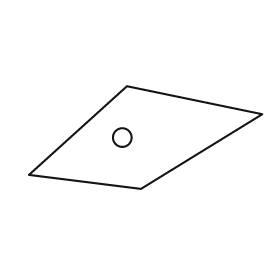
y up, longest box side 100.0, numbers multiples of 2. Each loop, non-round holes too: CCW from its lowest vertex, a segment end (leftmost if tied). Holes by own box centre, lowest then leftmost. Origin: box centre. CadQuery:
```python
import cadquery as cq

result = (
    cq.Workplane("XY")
    .moveTo(-2.0, -22.0)
    .lineTo(50.0, 10.0)
    .lineTo(-8.0, 22.0)
    .lineTo(-50.0, -16.0)
    .close()
    .moveTo(-10.0, 0.0)
    .circle(4.0)
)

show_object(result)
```